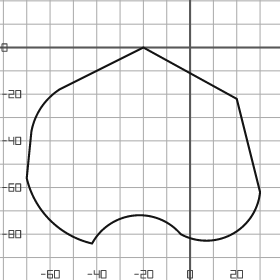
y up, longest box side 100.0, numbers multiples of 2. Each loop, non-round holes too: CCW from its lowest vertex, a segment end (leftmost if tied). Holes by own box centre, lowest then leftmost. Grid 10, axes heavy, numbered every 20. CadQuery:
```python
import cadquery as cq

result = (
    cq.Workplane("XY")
    .moveTo(-42.0, -84.0)
    .threePointArc((-24.0, -72.0), (-4.0, -80.0))
    .threePointArc((18.0, -80.0), (30.0, -62.0))
    .lineTo(20.0, -22.0)
    .lineTo(-20.0, 0.0)
    .lineTo(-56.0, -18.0)
    .threePointArc((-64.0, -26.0), (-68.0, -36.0))
    .lineTo(-70.0, -56.0)
    .threePointArc((-60.0, -74.0), (-42.0, -84.0))
    .close()
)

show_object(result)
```